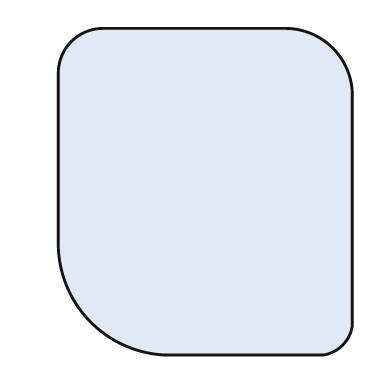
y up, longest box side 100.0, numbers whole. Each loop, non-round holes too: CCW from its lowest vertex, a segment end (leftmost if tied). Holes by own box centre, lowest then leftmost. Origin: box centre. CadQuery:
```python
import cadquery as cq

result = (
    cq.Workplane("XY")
    .moveTo(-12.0, -50.0)
    .lineTo(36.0, -50.0)
    .threePointArc((42.0, -47.0), (45.0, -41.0))
    .lineTo(45.0, 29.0)
    .threePointArc((39.0, 44.0), (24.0, 50.0))
    .lineTo(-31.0, 50.0)
    .threePointArc((-41.0, 46.0), (-45.0, 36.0))
    .lineTo(-45.0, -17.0)
    .threePointArc((-35.0, -40.0), (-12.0, -50.0))
    .close()
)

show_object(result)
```